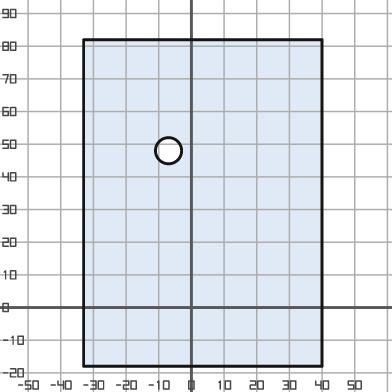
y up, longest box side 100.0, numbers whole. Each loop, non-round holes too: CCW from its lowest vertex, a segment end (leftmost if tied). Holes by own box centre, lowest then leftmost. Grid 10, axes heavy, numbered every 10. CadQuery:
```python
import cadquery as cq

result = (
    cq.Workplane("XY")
    .moveTo(-33.0, -18.0)
    .lineTo(40.0, -18.0)
    .lineTo(40.0, 82.0)
    .lineTo(-33.0, 82.0)
    .close()
    .moveTo(-7.0, 48.0)
    .circle(4.0)
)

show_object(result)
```